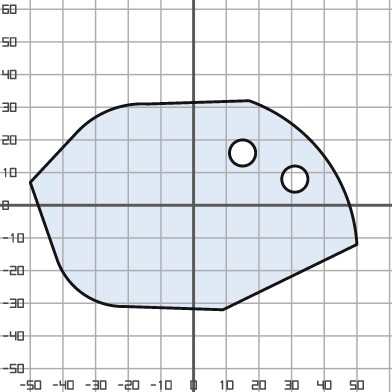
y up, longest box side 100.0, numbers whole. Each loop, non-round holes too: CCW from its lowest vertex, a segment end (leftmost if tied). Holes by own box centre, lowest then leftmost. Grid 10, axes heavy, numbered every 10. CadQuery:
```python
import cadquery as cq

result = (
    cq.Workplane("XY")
    .moveTo(9.0, -32.0)
    .lineTo(50.0, -12.0)
    .threePointArc((40.0, 15.0), (17.0, 32.0))
    .lineTo(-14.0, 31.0)
    .threePointArc((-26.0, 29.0), (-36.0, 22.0))
    .lineTo(-50.0, 7.0)
    .lineTo(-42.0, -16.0)
    .threePointArc((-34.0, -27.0), (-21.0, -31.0))
    .close()
    .moveTo(31.0, 8.0)
    .circle(4.0)
    .moveTo(15.0, 16.0)
    .circle(4.0)
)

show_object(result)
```